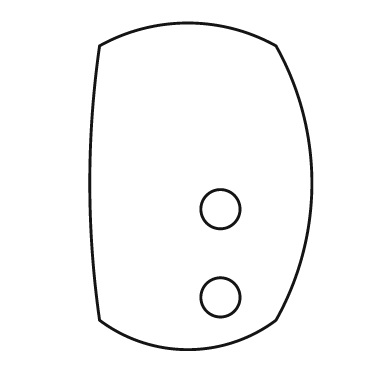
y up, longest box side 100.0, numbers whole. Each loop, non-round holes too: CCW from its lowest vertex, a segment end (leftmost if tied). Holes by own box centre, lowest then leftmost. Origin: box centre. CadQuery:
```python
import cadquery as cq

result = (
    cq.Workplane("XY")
    .moveTo(-31.0, -41.0)
    .threePointArc((-4.0, -50.0), (23.0, -41.0))
    .threePointArc((34.0, 1.0), (23.0, 43.0))
    .threePointArc((-4.0, 50.0), (-31.0, 43.0))
    .threePointArc((-34.0, 1.0), (-31.0, -41.0))
    .close()
    .moveTo(6.0, -34.0)
    .circle(6.0)
    .moveTo(6.0, -7.0)
    .circle(6.0)
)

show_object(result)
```